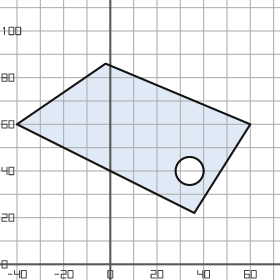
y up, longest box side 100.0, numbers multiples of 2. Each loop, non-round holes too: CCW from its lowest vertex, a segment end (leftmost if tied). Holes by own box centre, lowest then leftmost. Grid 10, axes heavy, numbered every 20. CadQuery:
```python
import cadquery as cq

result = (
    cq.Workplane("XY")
    .moveTo(36.0, 22.0)
    .lineTo(60.0, 60.0)
    .lineTo(-2.0, 86.0)
    .lineTo(-40.0, 60.0)
    .close()
    .moveTo(34.0, 40.0)
    .circle(6.0)
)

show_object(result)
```